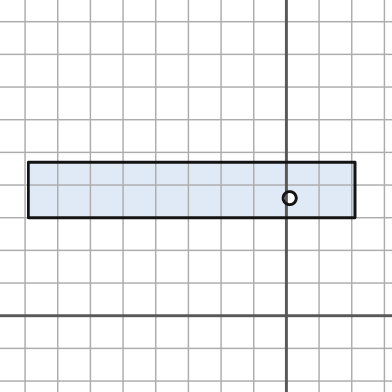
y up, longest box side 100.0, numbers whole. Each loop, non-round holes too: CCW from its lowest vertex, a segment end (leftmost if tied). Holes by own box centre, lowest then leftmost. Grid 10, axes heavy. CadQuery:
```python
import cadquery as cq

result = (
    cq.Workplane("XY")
    .moveTo(-79.0, 30.0)
    .lineTo(21.0, 30.0)
    .lineTo(21.0, 47.0)
    .lineTo(-79.0, 47.0)
    .close()
    .moveTo(1.0, 36.0)
    .circle(2.0)
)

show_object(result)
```